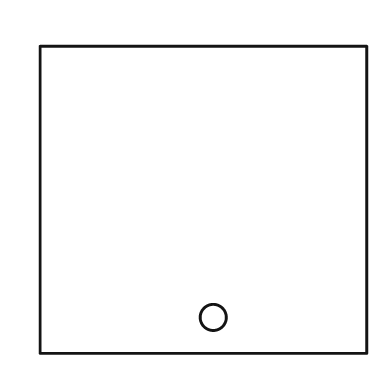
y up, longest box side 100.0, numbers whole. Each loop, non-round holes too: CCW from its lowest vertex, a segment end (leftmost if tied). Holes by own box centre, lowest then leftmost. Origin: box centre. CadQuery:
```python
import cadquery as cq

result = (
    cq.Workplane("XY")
    .moveTo(-50.0, -47.0)
    .lineTo(50.0, -47.0)
    .lineTo(50.0, 47.0)
    .lineTo(-50.0, 47.0)
    .close()
    .moveTo(3.0, -36.0)
    .circle(4.0)
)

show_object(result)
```